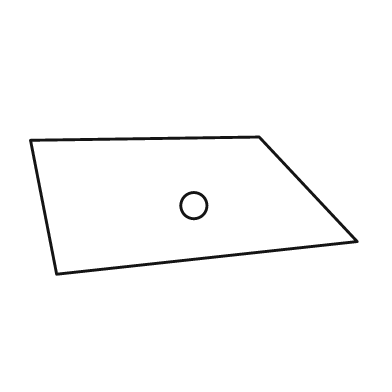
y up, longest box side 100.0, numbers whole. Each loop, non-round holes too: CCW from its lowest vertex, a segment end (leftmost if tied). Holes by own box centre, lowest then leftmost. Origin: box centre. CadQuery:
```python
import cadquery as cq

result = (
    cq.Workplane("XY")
    .moveTo(-42.0, -21.0)
    .lineTo(50.0, -11.0)
    .lineTo(20.0, 21.0)
    .lineTo(-50.0, 20.0)
    .close()
    .moveTo(0.0, 0.0)
    .circle(4.0)
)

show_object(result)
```